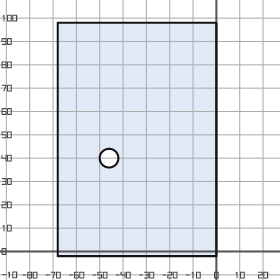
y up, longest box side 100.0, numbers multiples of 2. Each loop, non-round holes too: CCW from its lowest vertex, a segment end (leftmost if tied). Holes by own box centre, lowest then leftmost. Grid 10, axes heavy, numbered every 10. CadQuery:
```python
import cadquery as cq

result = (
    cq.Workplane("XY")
    .moveTo(-68.0, -2.0)
    .lineTo(0.0, -2.0)
    .lineTo(0.0, 98.0)
    .lineTo(-68.0, 98.0)
    .close()
    .moveTo(-46.0, 40.0)
    .circle(4.0)
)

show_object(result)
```